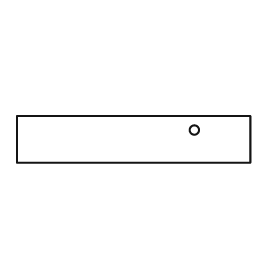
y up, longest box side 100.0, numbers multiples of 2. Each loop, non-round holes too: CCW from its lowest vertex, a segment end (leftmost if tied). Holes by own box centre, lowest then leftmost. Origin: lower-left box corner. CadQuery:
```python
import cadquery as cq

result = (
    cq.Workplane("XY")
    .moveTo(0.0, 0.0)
    .lineTo(100.0, 0.0)
    .lineTo(100.0, 20.0)
    .lineTo(0.0, 20.0)
    .close()
    .moveTo(76.0, 14.0)
    .circle(2.0)
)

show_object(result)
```